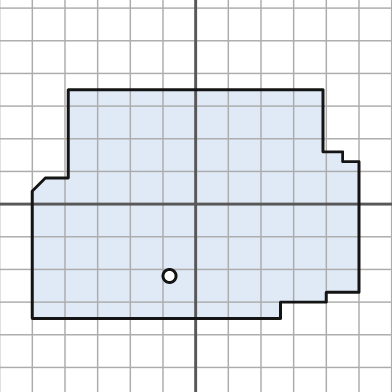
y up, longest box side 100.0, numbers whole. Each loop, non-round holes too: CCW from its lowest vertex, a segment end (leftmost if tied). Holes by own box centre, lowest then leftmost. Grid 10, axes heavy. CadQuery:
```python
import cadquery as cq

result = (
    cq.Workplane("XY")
    .moveTo(-50.0, -35.0)
    .lineTo(26.0, -35.0)
    .lineTo(26.0, -30.0)
    .lineTo(40.0, -30.0)
    .lineTo(40.0, -27.0)
    .lineTo(50.0, -27.0)
    .lineTo(50.0, 13.0)
    .lineTo(45.0, 13.0)
    .lineTo(45.0, 16.0)
    .lineTo(39.0, 16.0)
    .lineTo(39.0, 35.0)
    .lineTo(-39.0, 35.0)
    .lineTo(-39.0, 8.0)
    .lineTo(-46.0, 8.0)
    .lineTo(-50.0, 4.0)
    .close()
    .moveTo(-8.0, -22.0)
    .circle(2.0)
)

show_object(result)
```